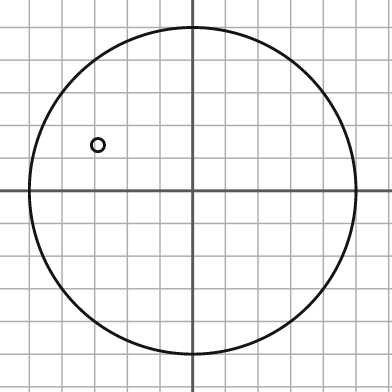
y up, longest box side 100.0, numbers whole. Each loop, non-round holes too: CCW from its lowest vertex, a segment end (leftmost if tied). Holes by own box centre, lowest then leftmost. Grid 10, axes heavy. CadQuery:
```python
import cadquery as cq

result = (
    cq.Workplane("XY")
    .moveTo(0.0, 0.0)
    .circle(50.0)
    .moveTo(-29.0, 14.0)
    .circle(2.0)
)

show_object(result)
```